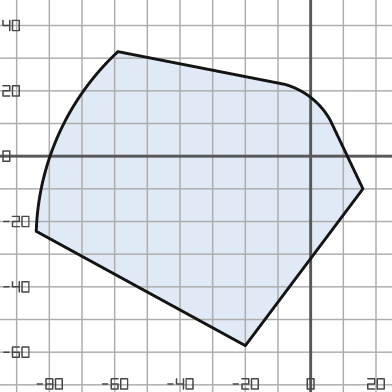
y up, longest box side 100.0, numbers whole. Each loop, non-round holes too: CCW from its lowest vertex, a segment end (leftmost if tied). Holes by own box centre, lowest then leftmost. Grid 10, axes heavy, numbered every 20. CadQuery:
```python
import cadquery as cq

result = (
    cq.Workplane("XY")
    .moveTo(-20.0, -58.0)
    .lineTo(16.0, -10.0)
    .lineTo(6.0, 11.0)
    .threePointArc((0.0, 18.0), (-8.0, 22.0))
    .lineTo(-59.0, 32.0)
    .threePointArc((-77.0, 7.0), (-84.0, -23.0))
    .close()
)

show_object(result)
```